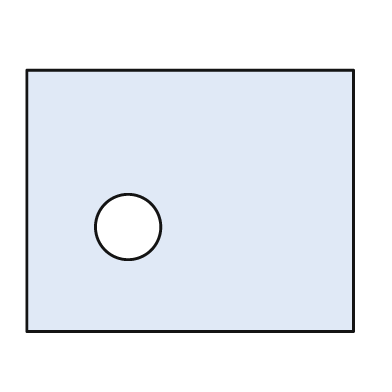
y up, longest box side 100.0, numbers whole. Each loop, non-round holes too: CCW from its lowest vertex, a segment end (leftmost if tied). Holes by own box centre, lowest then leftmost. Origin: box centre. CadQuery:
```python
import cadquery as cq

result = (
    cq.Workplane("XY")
    .moveTo(-50.0, -40.0)
    .lineTo(50.0, -40.0)
    .lineTo(50.0, 40.0)
    .lineTo(-50.0, 40.0)
    .close()
    .moveTo(-19.0, -8.0)
    .circle(10.0)
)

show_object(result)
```